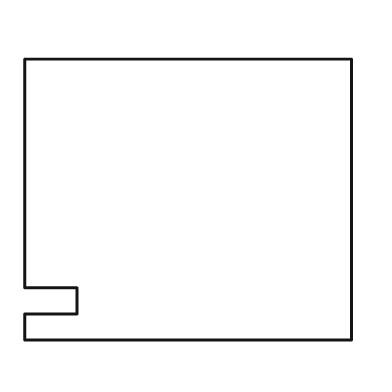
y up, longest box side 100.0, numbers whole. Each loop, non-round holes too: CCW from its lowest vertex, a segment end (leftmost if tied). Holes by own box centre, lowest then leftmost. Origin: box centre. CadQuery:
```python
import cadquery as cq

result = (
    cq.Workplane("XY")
    .moveTo(-50.0, -43.0)
    .lineTo(50.0, -43.0)
    .lineTo(50.0, 43.0)
    .lineTo(-50.0, 43.0)
    .lineTo(-50.0, -27.0)
    .lineTo(-34.0, -27.0)
    .lineTo(-34.0, -35.0)
    .lineTo(-50.0, -35.0)
    .close()
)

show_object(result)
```